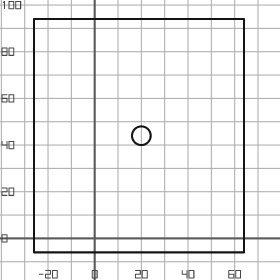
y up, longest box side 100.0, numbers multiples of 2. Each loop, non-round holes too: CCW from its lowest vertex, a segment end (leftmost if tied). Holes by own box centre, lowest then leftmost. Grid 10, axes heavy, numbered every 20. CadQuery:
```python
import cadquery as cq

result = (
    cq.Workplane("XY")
    .moveTo(-26.0, -6.0)
    .lineTo(64.0, -6.0)
    .lineTo(64.0, 94.0)
    .lineTo(-26.0, 94.0)
    .close()
    .moveTo(20.0, 44.0)
    .circle(4.0)
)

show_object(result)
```